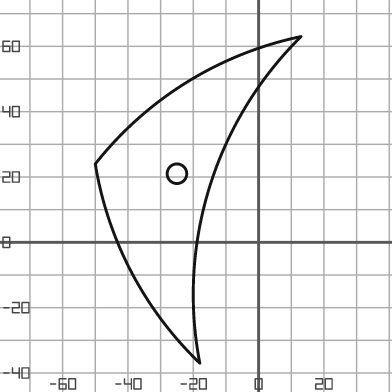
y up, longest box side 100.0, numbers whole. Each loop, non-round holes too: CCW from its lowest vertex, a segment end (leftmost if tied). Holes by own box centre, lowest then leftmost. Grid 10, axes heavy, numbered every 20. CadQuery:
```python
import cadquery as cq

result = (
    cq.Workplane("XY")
    .moveTo(-18.0, -37.0)
    .threePointArc((-15.0, 17.0), (13.0, 63.0))
    .threePointArc((-22.0, 49.0), (-50.0, 24.0))
    .threePointArc((-39.0, -9.0), (-18.0, -37.0))
    .close()
    .moveTo(-25.0, 21.0)
    .circle(3.0)
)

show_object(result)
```